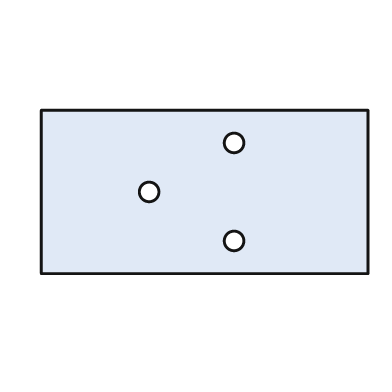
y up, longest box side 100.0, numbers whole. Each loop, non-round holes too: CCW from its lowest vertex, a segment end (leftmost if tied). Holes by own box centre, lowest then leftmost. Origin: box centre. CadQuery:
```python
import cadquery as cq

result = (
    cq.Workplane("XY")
    .moveTo(-50.0, -25.0)
    .lineTo(50.0, -25.0)
    .lineTo(50.0, 25.0)
    .lineTo(-50.0, 25.0)
    .close()
    .moveTo(9.0, -15.0)
    .circle(3.0)
    .moveTo(-17.0, 0.0)
    .circle(3.0)
    .moveTo(9.0, 15.0)
    .circle(3.0)
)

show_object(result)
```